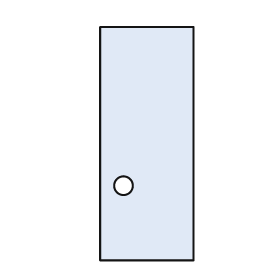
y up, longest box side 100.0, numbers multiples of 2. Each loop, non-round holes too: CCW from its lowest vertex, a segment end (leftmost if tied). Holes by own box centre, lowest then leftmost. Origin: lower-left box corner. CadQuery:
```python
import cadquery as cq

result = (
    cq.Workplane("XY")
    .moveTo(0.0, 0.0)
    .lineTo(40.0, 0.0)
    .lineTo(40.0, 100.0)
    .lineTo(0.0, 100.0)
    .close()
    .moveTo(10.0, 32.0)
    .circle(4.0)
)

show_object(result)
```